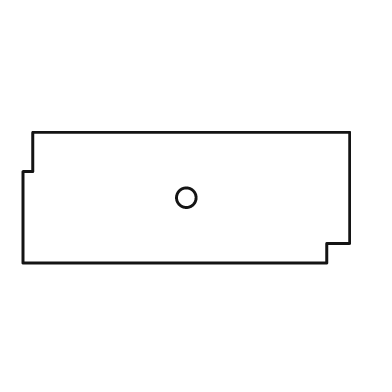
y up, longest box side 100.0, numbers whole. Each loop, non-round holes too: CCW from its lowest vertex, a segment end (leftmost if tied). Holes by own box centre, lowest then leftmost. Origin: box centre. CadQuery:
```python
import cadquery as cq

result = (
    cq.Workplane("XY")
    .moveTo(-50.0, -20.0)
    .lineTo(43.0, -20.0)
    .lineTo(43.0, -14.0)
    .lineTo(50.0, -14.0)
    .lineTo(50.0, 20.0)
    .lineTo(-47.0, 20.0)
    .lineTo(-47.0, 8.0)
    .lineTo(-50.0, 8.0)
    .close()
    .moveTo(0.0, 0.0)
    .circle(3.0)
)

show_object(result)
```